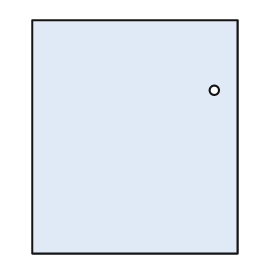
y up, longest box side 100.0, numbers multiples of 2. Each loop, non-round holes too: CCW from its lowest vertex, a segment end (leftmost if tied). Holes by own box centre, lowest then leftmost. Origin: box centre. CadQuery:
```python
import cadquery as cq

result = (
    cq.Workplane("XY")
    .moveTo(-44.0, -50.0)
    .lineTo(44.0, -50.0)
    .lineTo(44.0, 50.0)
    .lineTo(-44.0, 50.0)
    .close()
    .moveTo(34.0, 20.0)
    .circle(2.0)
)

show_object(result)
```